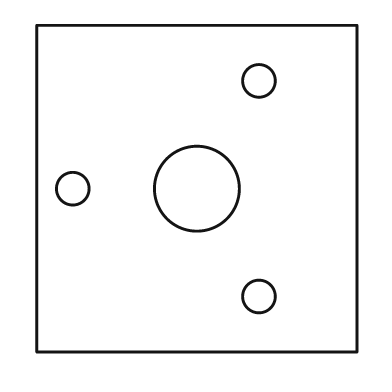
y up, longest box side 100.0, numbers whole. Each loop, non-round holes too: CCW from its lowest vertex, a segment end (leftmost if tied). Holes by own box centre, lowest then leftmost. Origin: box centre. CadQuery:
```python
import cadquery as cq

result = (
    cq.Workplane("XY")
    .moveTo(-49.0, -50.0)
    .lineTo(49.0, -50.0)
    .lineTo(49.0, 50.0)
    .lineTo(-49.0, 50.0)
    .close()
    .moveTo(19.0, -33.0)
    .circle(5.0)
    .moveTo(-38.0, 0.0)
    .circle(5.0)
    .moveTo(0.0, 0.0)
    .circle(13.0)
    .moveTo(19.0, 33.0)
    .circle(5.0)
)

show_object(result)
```